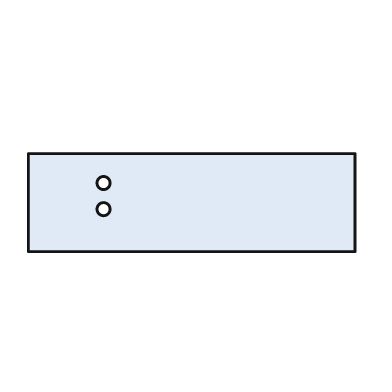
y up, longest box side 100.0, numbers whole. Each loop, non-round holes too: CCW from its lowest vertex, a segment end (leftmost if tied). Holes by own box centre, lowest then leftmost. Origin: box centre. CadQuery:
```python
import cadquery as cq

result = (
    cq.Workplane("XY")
    .moveTo(-50.0, -15.0)
    .lineTo(50.0, -15.0)
    .lineTo(50.0, 15.0)
    .lineTo(-50.0, 15.0)
    .close()
    .moveTo(-27.0, -2.0)
    .circle(2.0)
    .moveTo(-27.0, 6.0)
    .circle(2.0)
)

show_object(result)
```